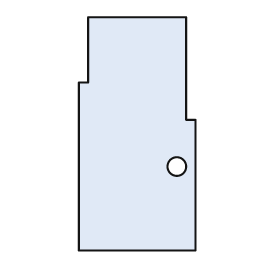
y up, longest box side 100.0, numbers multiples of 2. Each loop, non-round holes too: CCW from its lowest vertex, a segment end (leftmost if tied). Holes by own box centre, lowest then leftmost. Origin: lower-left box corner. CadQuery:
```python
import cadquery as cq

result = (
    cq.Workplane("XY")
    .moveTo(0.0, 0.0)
    .lineTo(50.0, 0.0)
    .lineTo(50.0, 56.0)
    .lineTo(46.0, 56.0)
    .lineTo(46.0, 100.0)
    .lineTo(4.0, 100.0)
    .lineTo(4.0, 72.0)
    .lineTo(0.0, 72.0)
    .close()
    .moveTo(42.0, 36.0)
    .circle(4.0)
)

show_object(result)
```